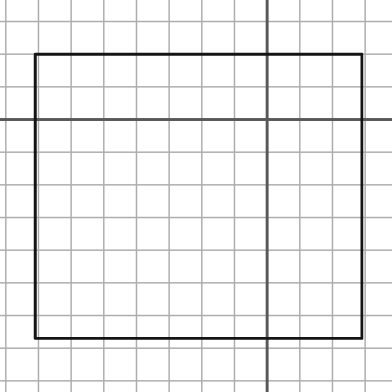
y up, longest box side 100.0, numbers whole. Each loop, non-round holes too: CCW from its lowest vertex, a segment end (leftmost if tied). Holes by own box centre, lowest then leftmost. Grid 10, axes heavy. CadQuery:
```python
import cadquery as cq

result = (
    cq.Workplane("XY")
    .moveTo(-71.0, -67.0)
    .lineTo(29.0, -67.0)
    .lineTo(29.0, 20.0)
    .lineTo(-71.0, 20.0)
    .close()
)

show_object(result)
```